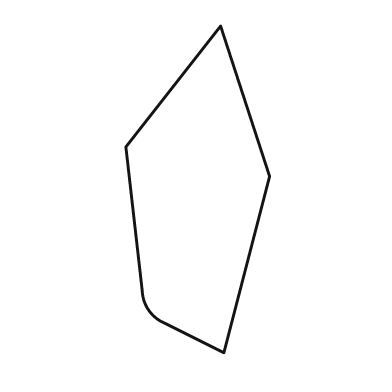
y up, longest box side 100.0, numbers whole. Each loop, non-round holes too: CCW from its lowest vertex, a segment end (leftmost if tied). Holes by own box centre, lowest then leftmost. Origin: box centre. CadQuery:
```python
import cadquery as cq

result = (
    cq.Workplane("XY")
    .moveTo(8.0, -50.0)
    .lineTo(22.0, 4.0)
    .lineTo(7.0, 50.0)
    .lineTo(-22.0, 13.0)
    .lineTo(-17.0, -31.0)
    .threePointArc((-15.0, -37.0), (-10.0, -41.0))
    .close()
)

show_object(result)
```